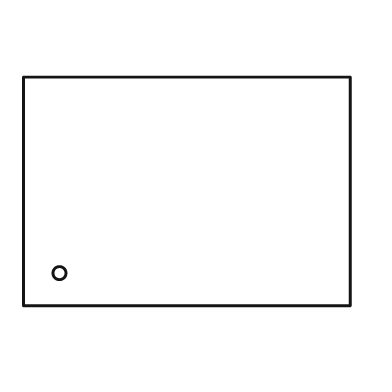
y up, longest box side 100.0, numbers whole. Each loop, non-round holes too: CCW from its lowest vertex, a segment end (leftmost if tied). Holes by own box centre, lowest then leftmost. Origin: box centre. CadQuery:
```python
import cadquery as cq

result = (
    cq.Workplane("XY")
    .moveTo(-50.0, -35.0)
    .lineTo(50.0, -35.0)
    .lineTo(50.0, 35.0)
    .lineTo(-50.0, 35.0)
    .close()
    .moveTo(-39.0, -25.0)
    .circle(2.0)
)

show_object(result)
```